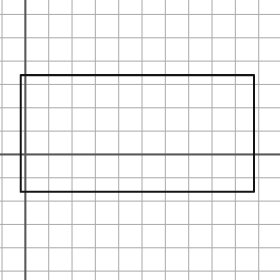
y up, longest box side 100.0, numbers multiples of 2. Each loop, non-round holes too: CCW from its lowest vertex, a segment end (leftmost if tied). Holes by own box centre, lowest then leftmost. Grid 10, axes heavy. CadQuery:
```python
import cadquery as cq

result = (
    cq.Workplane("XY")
    .moveTo(-2.0, -16.0)
    .lineTo(98.0, -16.0)
    .lineTo(98.0, 34.0)
    .lineTo(-2.0, 34.0)
    .close()
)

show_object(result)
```